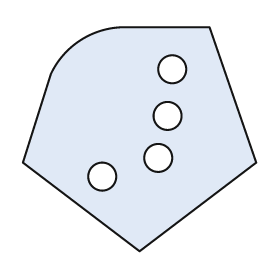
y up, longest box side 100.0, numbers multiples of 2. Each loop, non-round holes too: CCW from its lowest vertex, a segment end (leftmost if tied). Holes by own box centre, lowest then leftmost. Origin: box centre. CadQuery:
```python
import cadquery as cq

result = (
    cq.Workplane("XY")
    .moveTo(0.0, -48.0)
    .lineTo(50.0, -10.0)
    .lineTo(30.0, 48.0)
    .lineTo(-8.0, 48.0)
    .threePointArc((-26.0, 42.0), (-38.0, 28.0))
    .lineTo(-50.0, -10.0)
    .close()
    .moveTo(-16.0, -16.0)
    .circle(6.0)
    .moveTo(8.0, -8.0)
    .circle(6.0)
    .moveTo(12.0, 10.0)
    .circle(6.0)
    .moveTo(14.0, 30.0)
    .circle(6.0)
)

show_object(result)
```